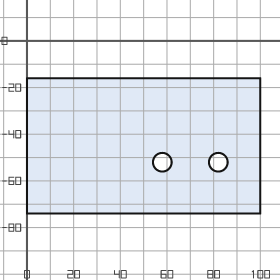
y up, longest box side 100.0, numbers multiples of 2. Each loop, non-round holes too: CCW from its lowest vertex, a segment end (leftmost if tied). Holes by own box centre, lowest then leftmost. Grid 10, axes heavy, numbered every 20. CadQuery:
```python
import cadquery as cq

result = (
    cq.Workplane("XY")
    .moveTo(0.0, -74.0)
    .lineTo(100.0, -74.0)
    .lineTo(100.0, -16.0)
    .lineTo(0.0, -16.0)
    .close()
    .moveTo(58.0, -52.0)
    .circle(4.0)
    .moveTo(82.0, -52.0)
    .circle(4.0)
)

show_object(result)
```